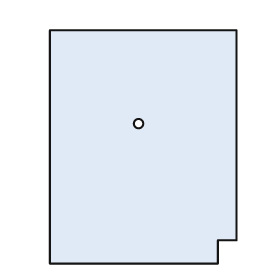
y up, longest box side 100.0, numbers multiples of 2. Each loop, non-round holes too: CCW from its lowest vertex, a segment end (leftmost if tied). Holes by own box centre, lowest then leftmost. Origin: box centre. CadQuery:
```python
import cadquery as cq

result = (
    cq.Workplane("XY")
    .moveTo(-40.0, -50.0)
    .lineTo(32.0, -50.0)
    .lineTo(32.0, -40.0)
    .lineTo(40.0, -40.0)
    .lineTo(40.0, 50.0)
    .lineTo(-40.0, 50.0)
    .close()
    .moveTo(-2.0, 10.0)
    .circle(2.0)
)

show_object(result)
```